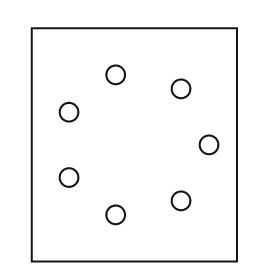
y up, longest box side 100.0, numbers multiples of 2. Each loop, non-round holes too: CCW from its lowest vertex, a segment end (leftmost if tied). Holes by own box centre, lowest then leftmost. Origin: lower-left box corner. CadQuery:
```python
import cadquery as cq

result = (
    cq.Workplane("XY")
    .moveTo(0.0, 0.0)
    .lineTo(88.0, 0.0)
    .lineTo(88.0, 100.0)
    .lineTo(0.0, 100.0)
    .close()
    .moveTo(36.0, 20.0)
    .circle(4.0)
    .moveTo(64.0, 26.0)
    .circle(4.0)
    .moveTo(16.0, 36.0)
    .circle(4.0)
    .moveTo(76.0, 50.0)
    .circle(4.0)
    .moveTo(16.0, 64.0)
    .circle(4.0)
    .moveTo(64.0, 74.0)
    .circle(4.0)
    .moveTo(36.0, 80.0)
    .circle(4.0)
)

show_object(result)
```